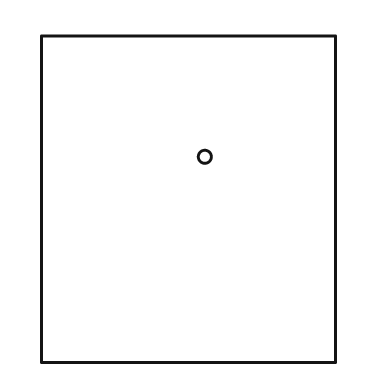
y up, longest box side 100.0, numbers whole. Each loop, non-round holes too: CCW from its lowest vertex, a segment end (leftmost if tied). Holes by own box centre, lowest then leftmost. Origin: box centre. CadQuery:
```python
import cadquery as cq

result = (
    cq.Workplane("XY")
    .moveTo(-45.0, -50.0)
    .lineTo(45.0, -50.0)
    .lineTo(45.0, 50.0)
    .lineTo(-45.0, 50.0)
    .close()
    .moveTo(5.0, 13.0)
    .circle(2.0)
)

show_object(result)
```